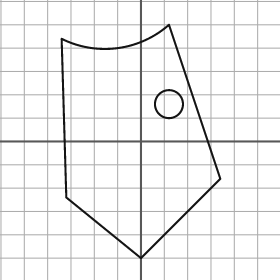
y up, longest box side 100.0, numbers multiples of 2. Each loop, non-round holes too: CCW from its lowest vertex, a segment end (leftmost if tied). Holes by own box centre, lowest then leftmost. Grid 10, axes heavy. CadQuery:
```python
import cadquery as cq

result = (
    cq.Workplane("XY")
    .moveTo(0.0, -50.0)
    .lineTo(34.0, -16.0)
    .lineTo(12.0, 50.0)
    .threePointArc((-10.0, 40.0), (-34.0, 44.0))
    .lineTo(-32.0, -24.0)
    .close()
    .moveTo(12.0, 16.0)
    .circle(6.0)
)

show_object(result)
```